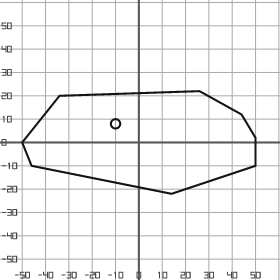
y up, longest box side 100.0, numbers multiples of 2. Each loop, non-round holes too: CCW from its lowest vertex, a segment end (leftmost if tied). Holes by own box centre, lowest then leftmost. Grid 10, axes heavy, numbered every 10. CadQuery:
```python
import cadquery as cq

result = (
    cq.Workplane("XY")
    .moveTo(14.0, -22.0)
    .lineTo(50.0, -10.0)
    .lineTo(50.0, 2.0)
    .lineTo(44.0, 12.0)
    .lineTo(26.0, 22.0)
    .lineTo(-34.0, 20.0)
    .lineTo(-50.0, 0.0)
    .lineTo(-46.0, -10.0)
    .close()
    .moveTo(-10.0, 8.0)
    .circle(2.0)
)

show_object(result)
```